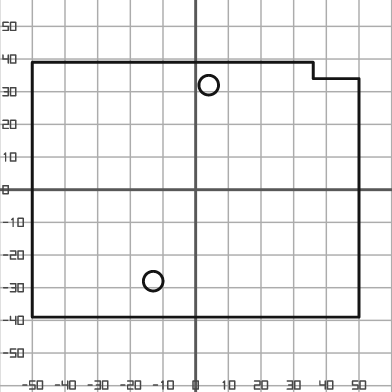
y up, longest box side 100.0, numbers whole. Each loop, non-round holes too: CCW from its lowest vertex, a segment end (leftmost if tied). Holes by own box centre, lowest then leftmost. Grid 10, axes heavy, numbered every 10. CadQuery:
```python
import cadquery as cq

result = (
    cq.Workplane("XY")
    .moveTo(-50.0, -39.0)
    .lineTo(50.0, -39.0)
    .lineTo(50.0, 34.0)
    .lineTo(36.0, 34.0)
    .lineTo(36.0, 39.0)
    .lineTo(-50.0, 39.0)
    .close()
    .moveTo(-13.0, -28.0)
    .circle(3.0)
    .moveTo(4.0, 32.0)
    .circle(3.0)
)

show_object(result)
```